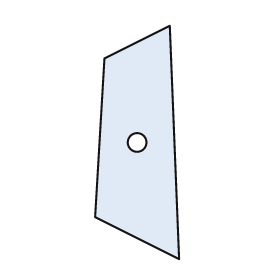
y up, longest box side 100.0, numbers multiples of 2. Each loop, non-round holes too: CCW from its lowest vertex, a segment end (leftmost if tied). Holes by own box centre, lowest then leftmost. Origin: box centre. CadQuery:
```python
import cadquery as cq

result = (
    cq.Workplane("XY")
    .moveTo(18.0, -50.0)
    .lineTo(14.0, 50.0)
    .lineTo(-14.0, 36.0)
    .lineTo(-18.0, -32.0)
    .close()
    .moveTo(0.0, 0.0)
    .circle(4.0)
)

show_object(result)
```